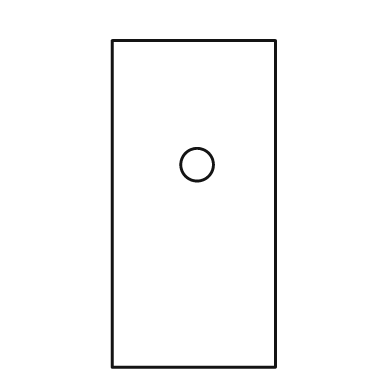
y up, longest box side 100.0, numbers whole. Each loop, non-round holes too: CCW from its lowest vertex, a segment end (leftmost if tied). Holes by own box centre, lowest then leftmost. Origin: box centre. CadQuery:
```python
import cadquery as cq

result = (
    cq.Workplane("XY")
    .moveTo(-25.0, -50.0)
    .lineTo(25.0, -50.0)
    .lineTo(25.0, 50.0)
    .lineTo(-25.0, 50.0)
    .close()
    .moveTo(1.0, 12.0)
    .circle(5.0)
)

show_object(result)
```